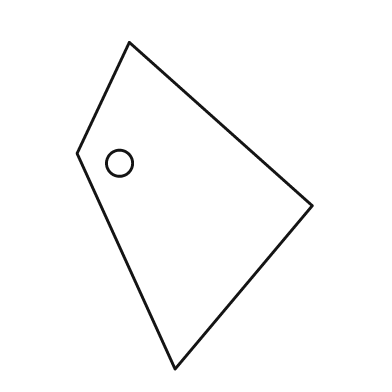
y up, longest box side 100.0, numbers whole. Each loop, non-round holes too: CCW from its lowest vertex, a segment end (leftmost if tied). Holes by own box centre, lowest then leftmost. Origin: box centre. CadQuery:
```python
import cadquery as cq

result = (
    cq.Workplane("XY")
    .moveTo(-6.0, -50.0)
    .lineTo(36.0, 0.0)
    .lineTo(-20.0, 50.0)
    .lineTo(-36.0, 16.0)
    .close()
    .moveTo(-23.0, 13.0)
    .circle(4.0)
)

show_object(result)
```